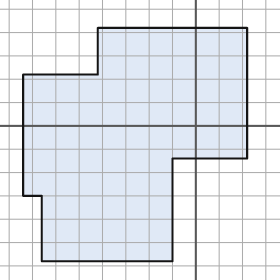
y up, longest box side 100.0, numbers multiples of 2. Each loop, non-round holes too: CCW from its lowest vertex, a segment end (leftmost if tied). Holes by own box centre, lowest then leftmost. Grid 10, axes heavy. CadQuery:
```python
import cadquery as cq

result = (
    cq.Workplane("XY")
    .moveTo(-66.0, -58.0)
    .lineTo(-10.0, -58.0)
    .lineTo(-10.0, -14.0)
    .lineTo(22.0, -14.0)
    .lineTo(22.0, 42.0)
    .lineTo(-42.0, 42.0)
    .lineTo(-42.0, 22.0)
    .lineTo(-74.0, 22.0)
    .lineTo(-74.0, -30.0)
    .lineTo(-66.0, -30.0)
    .close()
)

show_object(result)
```